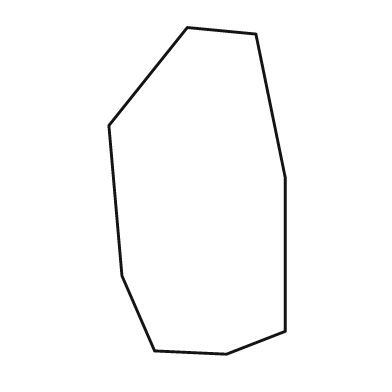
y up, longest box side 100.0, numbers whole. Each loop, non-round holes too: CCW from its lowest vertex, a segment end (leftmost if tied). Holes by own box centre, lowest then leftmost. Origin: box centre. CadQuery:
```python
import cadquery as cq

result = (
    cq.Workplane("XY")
    .moveTo(9.0, -50.0)
    .lineTo(27.0, -43.0)
    .lineTo(27.0, 4.0)
    .lineTo(18.0, 48.0)
    .lineTo(-3.0, 50.0)
    .lineTo(-27.0, 20.0)
    .lineTo(-23.0, -26.0)
    .lineTo(-13.0, -49.0)
    .close()
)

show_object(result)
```